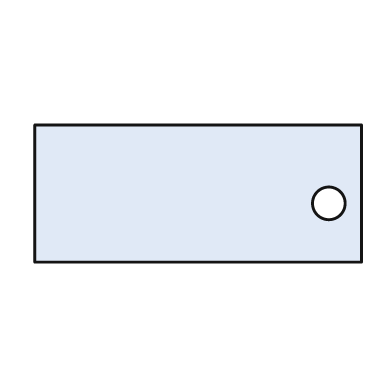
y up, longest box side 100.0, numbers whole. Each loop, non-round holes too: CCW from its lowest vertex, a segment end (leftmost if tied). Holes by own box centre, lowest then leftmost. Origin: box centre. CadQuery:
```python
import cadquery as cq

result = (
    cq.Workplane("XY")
    .moveTo(-50.0, -21.0)
    .lineTo(50.0, -21.0)
    .lineTo(50.0, 21.0)
    .lineTo(-50.0, 21.0)
    .close()
    .moveTo(40.0, -3.0)
    .circle(5.0)
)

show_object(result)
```